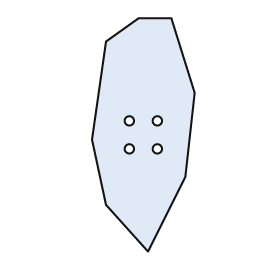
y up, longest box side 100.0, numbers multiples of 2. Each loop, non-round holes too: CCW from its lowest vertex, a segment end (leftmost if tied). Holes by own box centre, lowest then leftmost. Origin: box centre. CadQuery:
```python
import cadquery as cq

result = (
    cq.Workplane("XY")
    .moveTo(2.0, -50.0)
    .lineTo(18.0, -18.0)
    .lineTo(22.0, 18.0)
    .lineTo(12.0, 50.0)
    .lineTo(-2.0, 50.0)
    .lineTo(-16.0, 40.0)
    .lineTo(-22.0, -2.0)
    .lineTo(-16.0, -30.0)
    .close()
    .moveTo(-6.0, -6.0)
    .circle(2.0)
    .moveTo(6.0, -6.0)
    .circle(2.0)
    .moveTo(-6.0, 6.0)
    .circle(2.0)
    .moveTo(6.0, 6.0)
    .circle(2.0)
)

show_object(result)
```